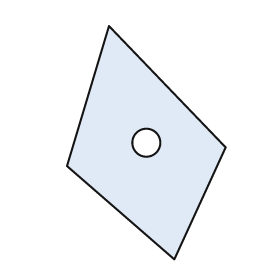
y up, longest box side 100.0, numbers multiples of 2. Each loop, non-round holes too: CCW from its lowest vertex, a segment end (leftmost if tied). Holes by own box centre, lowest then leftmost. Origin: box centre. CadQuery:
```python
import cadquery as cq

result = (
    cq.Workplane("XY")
    .moveTo(12.0, -50.0)
    .lineTo(34.0, -2.0)
    .lineTo(-16.0, 50.0)
    .lineTo(-34.0, -10.0)
    .close()
    .moveTo(0.0, 0.0)
    .circle(6.0)
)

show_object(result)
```